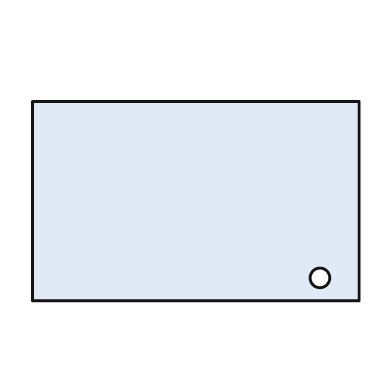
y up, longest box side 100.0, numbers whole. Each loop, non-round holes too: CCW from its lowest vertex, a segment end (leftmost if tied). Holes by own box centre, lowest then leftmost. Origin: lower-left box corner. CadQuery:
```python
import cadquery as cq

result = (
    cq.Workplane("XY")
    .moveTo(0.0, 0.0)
    .lineTo(100.0, 0.0)
    .lineTo(100.0, 61.0)
    .lineTo(0.0, 61.0)
    .close()
    .moveTo(88.0, 7.0)
    .circle(3.0)
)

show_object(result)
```